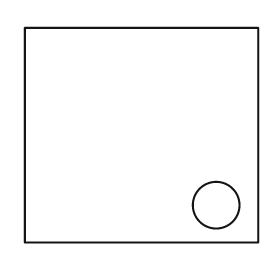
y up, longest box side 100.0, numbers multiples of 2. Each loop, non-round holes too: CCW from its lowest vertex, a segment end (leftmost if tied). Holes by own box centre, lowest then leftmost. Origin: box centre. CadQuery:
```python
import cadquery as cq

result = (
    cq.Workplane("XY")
    .moveTo(-50.0, -46.0)
    .lineTo(50.0, -46.0)
    .lineTo(50.0, 46.0)
    .lineTo(-50.0, 46.0)
    .close()
    .moveTo(32.0, -30.0)
    .circle(10.0)
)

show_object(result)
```